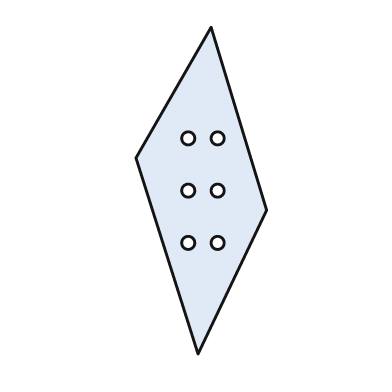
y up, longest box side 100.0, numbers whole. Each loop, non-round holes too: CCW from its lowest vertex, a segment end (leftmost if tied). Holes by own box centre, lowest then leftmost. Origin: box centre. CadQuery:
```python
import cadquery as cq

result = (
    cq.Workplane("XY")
    .moveTo(-1.0, -50.0)
    .lineTo(20.0, -6.0)
    .lineTo(3.0, 50.0)
    .lineTo(-20.0, 10.0)
    .close()
    .moveTo(-4.0, -16.0)
    .circle(2.0)
    .moveTo(5.0, -16.0)
    .circle(2.0)
    .moveTo(-4.0, 0.0)
    .circle(2.0)
    .moveTo(5.0, 0.0)
    .circle(2.0)
    .moveTo(-4.0, 16.0)
    .circle(2.0)
    .moveTo(5.0, 16.0)
    .circle(2.0)
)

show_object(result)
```